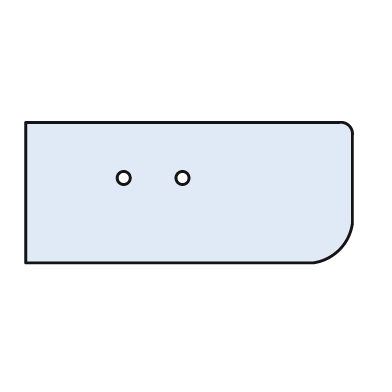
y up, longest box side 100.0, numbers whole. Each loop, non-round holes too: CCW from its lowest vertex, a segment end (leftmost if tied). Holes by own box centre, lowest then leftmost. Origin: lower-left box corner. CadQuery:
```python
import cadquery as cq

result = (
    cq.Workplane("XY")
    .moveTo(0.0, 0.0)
    .lineTo(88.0, 0.0)
    .threePointArc((96.0, 4.0), (100.0, 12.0))
    .lineTo(100.0, 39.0)
    .threePointArc((99.0, 42.0), (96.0, 43.0))
    .lineTo(0.0, 43.0)
    .close()
    .moveTo(30.0, 26.0)
    .circle(2.0)
    .moveTo(48.0, 26.0)
    .circle(2.0)
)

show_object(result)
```